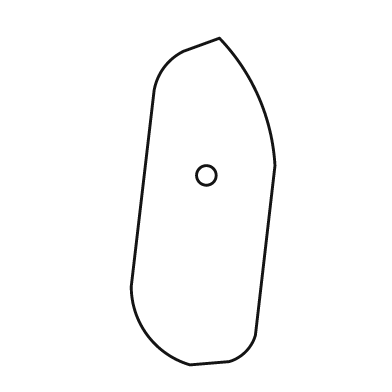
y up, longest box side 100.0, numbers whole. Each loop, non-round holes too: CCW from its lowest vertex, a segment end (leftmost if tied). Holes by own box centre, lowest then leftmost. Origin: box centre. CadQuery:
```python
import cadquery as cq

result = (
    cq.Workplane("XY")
    .moveTo(-4.0, -50.0)
    .lineTo(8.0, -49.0)
    .threePointArc((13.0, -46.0), (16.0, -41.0))
    .lineTo(22.0, 11.0)
    .threePointArc((17.0, 32.0), (5.0, 50.0))
    .lineTo(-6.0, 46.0)
    .threePointArc((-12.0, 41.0), (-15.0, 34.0))
    .lineTo(-22.0, -26.0)
    .threePointArc((-17.0, -41.0), (-4.0, -50.0))
    .close()
    .moveTo(1.0, 8.0)
    .circle(3.0)
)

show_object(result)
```